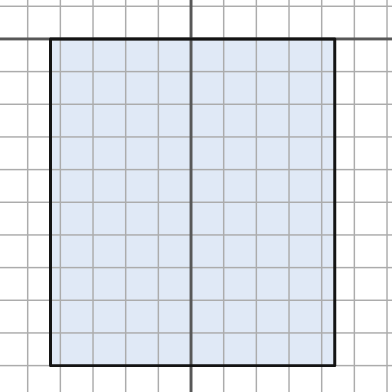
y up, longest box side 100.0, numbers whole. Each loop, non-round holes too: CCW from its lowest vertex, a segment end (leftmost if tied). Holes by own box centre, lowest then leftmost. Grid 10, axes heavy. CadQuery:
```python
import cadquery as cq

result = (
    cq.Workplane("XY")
    .moveTo(-43.0, -100.0)
    .lineTo(44.0, -100.0)
    .lineTo(44.0, 0.0)
    .lineTo(-43.0, 0.0)
    .close()
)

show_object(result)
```